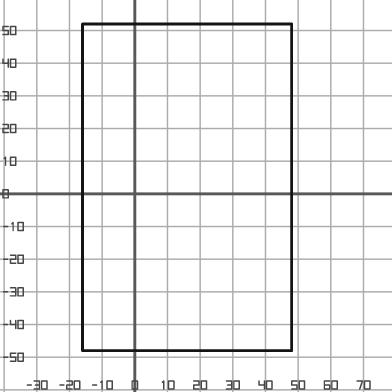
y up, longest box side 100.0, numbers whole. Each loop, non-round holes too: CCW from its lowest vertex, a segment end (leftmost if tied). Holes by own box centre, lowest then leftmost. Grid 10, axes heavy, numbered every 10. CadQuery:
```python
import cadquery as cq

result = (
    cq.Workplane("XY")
    .moveTo(-16.0, -48.0)
    .lineTo(48.0, -48.0)
    .lineTo(48.0, 52.0)
    .lineTo(-16.0, 52.0)
    .close()
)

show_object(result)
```